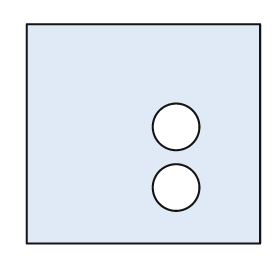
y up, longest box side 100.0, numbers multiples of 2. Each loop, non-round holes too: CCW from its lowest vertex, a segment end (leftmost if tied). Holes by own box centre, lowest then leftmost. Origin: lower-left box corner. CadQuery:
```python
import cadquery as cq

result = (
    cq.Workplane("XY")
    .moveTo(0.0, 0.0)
    .lineTo(100.0, 0.0)
    .lineTo(100.0, 94.0)
    .lineTo(0.0, 94.0)
    .close()
    .moveTo(64.0, 24.0)
    .circle(10.0)
    .moveTo(64.0, 50.0)
    .circle(10.0)
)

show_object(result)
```